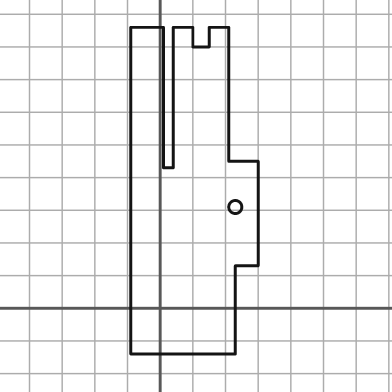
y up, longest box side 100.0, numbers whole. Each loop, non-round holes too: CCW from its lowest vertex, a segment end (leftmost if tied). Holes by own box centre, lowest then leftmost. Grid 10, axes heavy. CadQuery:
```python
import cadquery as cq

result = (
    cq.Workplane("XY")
    .moveTo(-9.0, -14.0)
    .lineTo(23.0, -14.0)
    .lineTo(23.0, 13.0)
    .lineTo(30.0, 13.0)
    .lineTo(30.0, 45.0)
    .lineTo(21.0, 45.0)
    .lineTo(21.0, 86.0)
    .lineTo(15.0, 86.0)
    .lineTo(15.0, 80.0)
    .lineTo(10.0, 80.0)
    .lineTo(10.0, 86.0)
    .lineTo(4.0, 86.0)
    .lineTo(4.0, 43.0)
    .lineTo(1.0, 43.0)
    .lineTo(1.0, 86.0)
    .lineTo(-9.0, 86.0)
    .close()
    .moveTo(23.0, 31.0)
    .circle(2.0)
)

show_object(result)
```